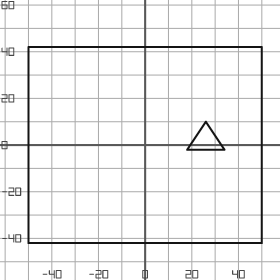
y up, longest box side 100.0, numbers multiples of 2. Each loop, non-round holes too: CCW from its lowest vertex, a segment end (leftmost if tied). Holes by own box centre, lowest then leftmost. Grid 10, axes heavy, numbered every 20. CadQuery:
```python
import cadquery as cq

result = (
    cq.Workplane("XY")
    .moveTo(-50.0, -42.0)
    .lineTo(50.0, -42.0)
    .lineTo(50.0, 42.0)
    .lineTo(-50.0, 42.0)
    .close()
    .moveTo(18.0, -2.0)
    .lineTo(34.0, -2.0)
    .lineTo(26.0, 10.0)
    .close()
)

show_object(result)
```